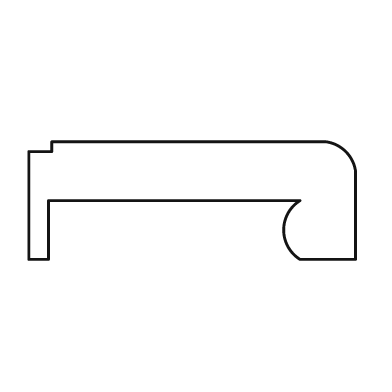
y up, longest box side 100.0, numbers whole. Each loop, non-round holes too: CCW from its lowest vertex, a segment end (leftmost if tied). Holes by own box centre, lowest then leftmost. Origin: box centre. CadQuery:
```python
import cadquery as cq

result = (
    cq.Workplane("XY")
    .moveTo(-50.0, -18.0)
    .lineTo(-44.0, -18.0)
    .lineTo(-44.0, 0.0)
    .lineTo(33.0, 0.0)
    .threePointArc((28.0, -9.0), (33.0, -18.0))
    .lineTo(50.0, -18.0)
    .lineTo(50.0, 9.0)
    .threePointArc((47.0, 15.0), (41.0, 18.0))
    .lineTo(-43.0, 18.0)
    .lineTo(-43.0, 15.0)
    .lineTo(-50.0, 15.0)
    .close()
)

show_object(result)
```